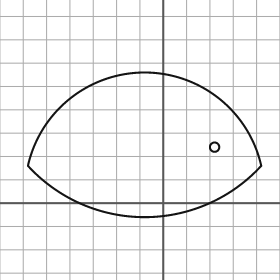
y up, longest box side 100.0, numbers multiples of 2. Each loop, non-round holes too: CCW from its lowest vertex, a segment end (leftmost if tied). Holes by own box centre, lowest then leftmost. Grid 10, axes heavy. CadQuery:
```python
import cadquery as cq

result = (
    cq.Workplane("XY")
    .moveTo(-58.0, 16.0)
    .threePointArc((-8.0, -6.0), (42.0, 16.0))
    .threePointArc((-8.0, 56.0), (-58.0, 16.0))
    .close()
    .moveTo(22.0, 24.0)
    .circle(2.0)
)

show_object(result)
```